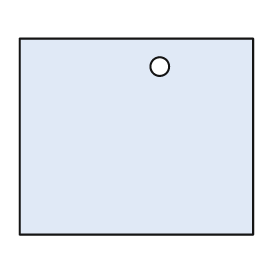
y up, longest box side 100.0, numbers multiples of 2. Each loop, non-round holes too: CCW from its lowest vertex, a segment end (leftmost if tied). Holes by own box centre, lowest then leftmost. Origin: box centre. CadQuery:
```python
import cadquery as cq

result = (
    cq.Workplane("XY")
    .moveTo(-50.0, -42.0)
    .lineTo(50.0, -42.0)
    .lineTo(50.0, 42.0)
    .lineTo(-50.0, 42.0)
    .close()
    .moveTo(10.0, 30.0)
    .circle(4.0)
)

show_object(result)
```